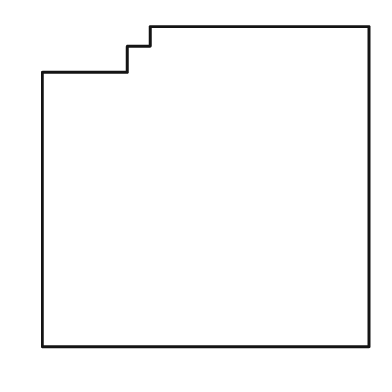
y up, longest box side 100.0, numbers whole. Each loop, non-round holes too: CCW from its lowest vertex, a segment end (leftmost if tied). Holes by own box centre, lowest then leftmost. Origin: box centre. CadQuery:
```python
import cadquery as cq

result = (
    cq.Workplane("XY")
    .moveTo(-50.0, -49.0)
    .lineTo(50.0, -49.0)
    .lineTo(50.0, 49.0)
    .lineTo(-17.0, 49.0)
    .lineTo(-17.0, 43.0)
    .lineTo(-24.0, 43.0)
    .lineTo(-24.0, 35.0)
    .lineTo(-50.0, 35.0)
    .close()
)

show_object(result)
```